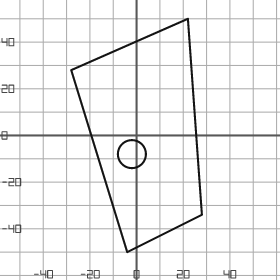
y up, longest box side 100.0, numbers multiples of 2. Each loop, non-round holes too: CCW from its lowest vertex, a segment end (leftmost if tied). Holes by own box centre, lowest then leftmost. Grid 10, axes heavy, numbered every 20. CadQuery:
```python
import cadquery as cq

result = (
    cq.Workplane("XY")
    .moveTo(-4.0, -50.0)
    .lineTo(28.0, -34.0)
    .lineTo(22.0, 50.0)
    .lineTo(-28.0, 28.0)
    .close()
    .moveTo(-2.0, -8.0)
    .circle(6.0)
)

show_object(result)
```